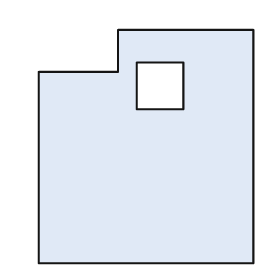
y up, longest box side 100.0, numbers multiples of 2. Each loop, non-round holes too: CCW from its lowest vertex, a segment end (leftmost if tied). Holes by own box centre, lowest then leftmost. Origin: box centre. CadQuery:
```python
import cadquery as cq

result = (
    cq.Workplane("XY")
    .moveTo(-46.0, -50.0)
    .lineTo(46.0, -50.0)
    .lineTo(46.0, 50.0)
    .lineTo(-12.0, 50.0)
    .lineTo(-12.0, 32.0)
    .lineTo(-46.0, 32.0)
    .close()
    .moveTo(-4.0, 16.0)
    .lineTo(16.0, 16.0)
    .lineTo(16.0, 36.0)
    .lineTo(-4.0, 36.0)
    .close()
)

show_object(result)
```